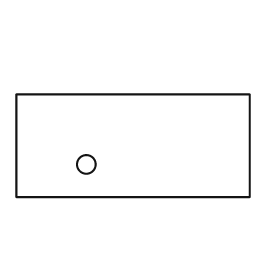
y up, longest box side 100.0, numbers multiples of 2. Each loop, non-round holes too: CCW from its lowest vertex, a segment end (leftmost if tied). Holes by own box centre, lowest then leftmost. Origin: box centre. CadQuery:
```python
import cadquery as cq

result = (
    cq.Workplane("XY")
    .moveTo(-50.0, -22.0)
    .lineTo(50.0, -22.0)
    .lineTo(50.0, 22.0)
    .lineTo(-50.0, 22.0)
    .close()
    .moveTo(-20.0, -8.0)
    .circle(4.0)
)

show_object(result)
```